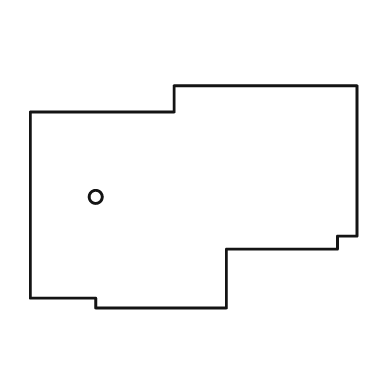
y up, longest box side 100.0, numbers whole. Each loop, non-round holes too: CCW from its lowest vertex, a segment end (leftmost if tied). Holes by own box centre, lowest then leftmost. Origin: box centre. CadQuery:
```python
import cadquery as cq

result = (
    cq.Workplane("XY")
    .moveTo(-30.0, -34.0)
    .lineTo(10.0, -34.0)
    .lineTo(10.0, -16.0)
    .lineTo(44.0, -16.0)
    .lineTo(44.0, -12.0)
    .lineTo(50.0, -12.0)
    .lineTo(50.0, 34.0)
    .lineTo(-6.0, 34.0)
    .lineTo(-6.0, 26.0)
    .lineTo(-50.0, 26.0)
    .lineTo(-50.0, -31.0)
    .lineTo(-30.0, -31.0)
    .close()
    .moveTo(-30.0, 0.0)
    .circle(2.0)
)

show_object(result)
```